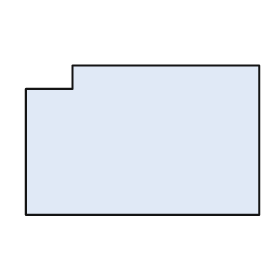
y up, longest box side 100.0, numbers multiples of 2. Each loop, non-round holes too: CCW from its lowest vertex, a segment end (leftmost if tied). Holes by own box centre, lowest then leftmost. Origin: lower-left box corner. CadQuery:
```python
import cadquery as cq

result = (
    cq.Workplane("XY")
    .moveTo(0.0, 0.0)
    .lineTo(100.0, 0.0)
    .lineTo(100.0, 64.0)
    .lineTo(20.0, 64.0)
    .lineTo(20.0, 54.0)
    .lineTo(0.0, 54.0)
    .close()
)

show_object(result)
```